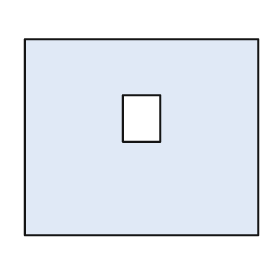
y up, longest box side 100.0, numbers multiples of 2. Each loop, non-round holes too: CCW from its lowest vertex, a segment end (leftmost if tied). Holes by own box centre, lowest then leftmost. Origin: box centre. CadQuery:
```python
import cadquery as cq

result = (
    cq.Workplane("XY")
    .moveTo(-50.0, -42.0)
    .lineTo(50.0, -42.0)
    .lineTo(50.0, 42.0)
    .lineTo(-50.0, 42.0)
    .close()
    .moveTo(-8.0, -2.0)
    .lineTo(8.0, -2.0)
    .lineTo(8.0, 18.0)
    .lineTo(-8.0, 18.0)
    .close()
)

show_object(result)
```